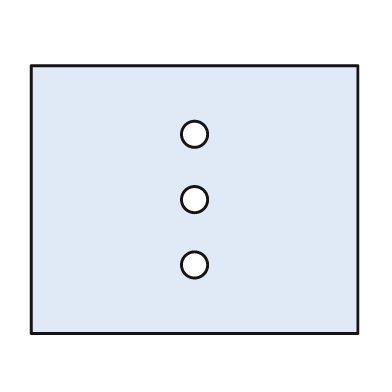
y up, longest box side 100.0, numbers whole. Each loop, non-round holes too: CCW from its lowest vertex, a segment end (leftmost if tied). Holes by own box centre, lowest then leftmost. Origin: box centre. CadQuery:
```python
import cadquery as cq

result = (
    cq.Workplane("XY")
    .moveTo(-50.0, -41.0)
    .lineTo(50.0, -41.0)
    .lineTo(50.0, 41.0)
    .lineTo(-50.0, 41.0)
    .close()
    .moveTo(0.0, -20.0)
    .circle(4.0)
    .moveTo(0.0, 0.0)
    .circle(4.0)
    .moveTo(0.0, 20.0)
    .circle(4.0)
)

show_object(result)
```